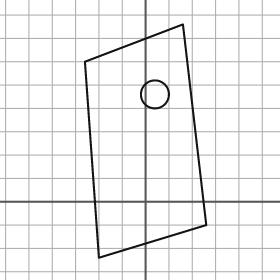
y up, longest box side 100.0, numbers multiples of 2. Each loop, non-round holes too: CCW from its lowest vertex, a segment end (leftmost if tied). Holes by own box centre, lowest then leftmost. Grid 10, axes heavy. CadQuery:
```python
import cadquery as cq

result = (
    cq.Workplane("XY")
    .moveTo(-20.0, -24.0)
    .lineTo(26.0, -10.0)
    .lineTo(16.0, 76.0)
    .lineTo(-26.0, 60.0)
    .close()
    .moveTo(4.0, 46.0)
    .circle(6.0)
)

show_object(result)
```